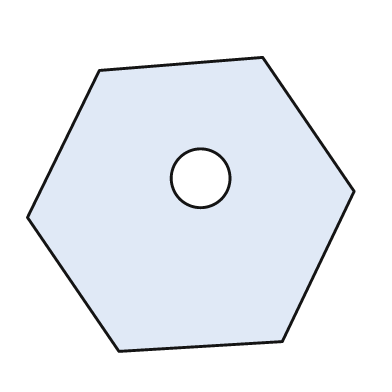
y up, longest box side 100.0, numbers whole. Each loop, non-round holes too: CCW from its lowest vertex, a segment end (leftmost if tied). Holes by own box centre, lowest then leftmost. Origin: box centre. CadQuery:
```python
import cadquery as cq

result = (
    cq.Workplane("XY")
    .moveTo(-22.0, -45.0)
    .lineTo(28.0, -42.0)
    .lineTo(50.0, 4.0)
    .lineTo(22.0, 45.0)
    .lineTo(-28.0, 41.0)
    .lineTo(-50.0, -4.0)
    .close()
    .moveTo(3.0, 8.0)
    .circle(9.0)
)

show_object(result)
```